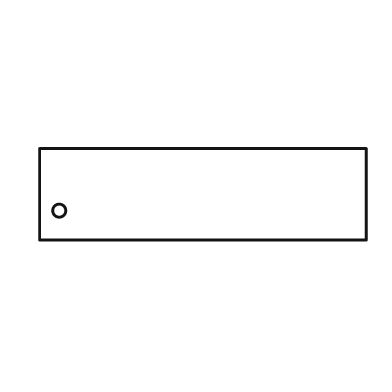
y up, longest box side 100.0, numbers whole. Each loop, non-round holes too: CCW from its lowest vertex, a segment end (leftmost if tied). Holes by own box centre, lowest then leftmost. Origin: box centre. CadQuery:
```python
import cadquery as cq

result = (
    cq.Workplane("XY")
    .moveTo(-50.0, -14.0)
    .lineTo(50.0, -14.0)
    .lineTo(50.0, 14.0)
    .lineTo(-50.0, 14.0)
    .close()
    .moveTo(-44.0, -5.0)
    .circle(2.0)
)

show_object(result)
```